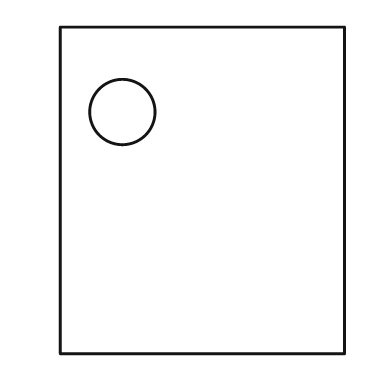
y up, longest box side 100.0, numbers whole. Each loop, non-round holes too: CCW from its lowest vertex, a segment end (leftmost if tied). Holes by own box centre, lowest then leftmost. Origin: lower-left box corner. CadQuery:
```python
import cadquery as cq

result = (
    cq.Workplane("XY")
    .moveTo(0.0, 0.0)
    .lineTo(87.0, 0.0)
    .lineTo(87.0, 100.0)
    .lineTo(0.0, 100.0)
    .close()
    .moveTo(19.0, 74.0)
    .circle(10.0)
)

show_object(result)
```